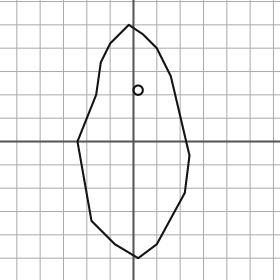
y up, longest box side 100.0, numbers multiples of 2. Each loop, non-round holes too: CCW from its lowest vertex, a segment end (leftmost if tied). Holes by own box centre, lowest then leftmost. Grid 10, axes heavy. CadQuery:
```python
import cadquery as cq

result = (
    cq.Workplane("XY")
    .moveTo(2.0, -50.0)
    .lineTo(10.0, -44.0)
    .lineTo(22.0, -22.0)
    .lineTo(24.0, -6.0)
    .lineTo(16.0, 28.0)
    .lineTo(10.0, 40.0)
    .lineTo(4.0, 46.0)
    .lineTo(-2.0, 50.0)
    .lineTo(-10.0, 42.0)
    .lineTo(-14.0, 34.0)
    .lineTo(-16.0, 20.0)
    .lineTo(-24.0, 0.0)
    .lineTo(-18.0, -34.0)
    .lineTo(-8.0, -44.0)
    .close()
    .moveTo(2.0, 22.0)
    .circle(2.0)
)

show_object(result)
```